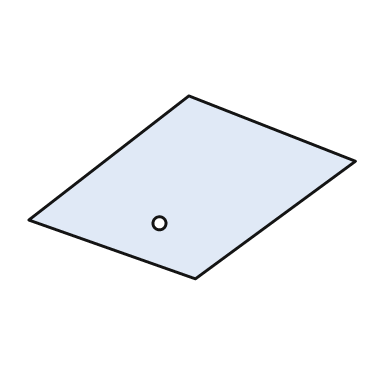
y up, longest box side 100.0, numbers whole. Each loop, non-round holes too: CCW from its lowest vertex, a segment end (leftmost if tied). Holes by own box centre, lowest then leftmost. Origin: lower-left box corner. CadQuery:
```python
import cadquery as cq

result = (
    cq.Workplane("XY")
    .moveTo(51.0, 0.0)
    .lineTo(100.0, 36.0)
    .lineTo(49.0, 56.0)
    .lineTo(0.0, 18.0)
    .close()
    .moveTo(40.0, 17.0)
    .circle(2.0)
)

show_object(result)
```